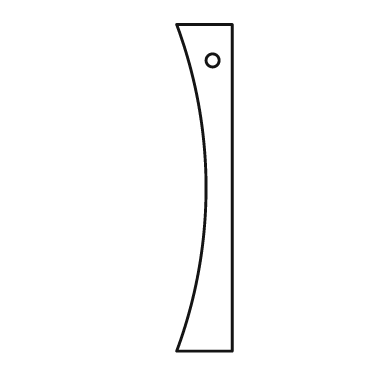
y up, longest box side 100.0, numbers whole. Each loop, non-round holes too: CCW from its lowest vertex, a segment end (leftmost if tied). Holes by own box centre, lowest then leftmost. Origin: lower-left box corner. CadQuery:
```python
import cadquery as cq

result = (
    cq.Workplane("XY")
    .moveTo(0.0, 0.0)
    .lineTo(17.0, 0.0)
    .lineTo(17.0, 100.0)
    .lineTo(0.0, 100.0)
    .threePointArc((9.0, 50.0), (0.0, 0.0))
    .close()
    .moveTo(11.0, 89.0)
    .circle(2.0)
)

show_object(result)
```